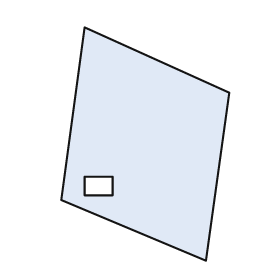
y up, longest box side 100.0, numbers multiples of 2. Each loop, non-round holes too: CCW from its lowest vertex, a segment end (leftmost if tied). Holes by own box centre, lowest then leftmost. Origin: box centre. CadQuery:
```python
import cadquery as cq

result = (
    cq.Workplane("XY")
    .moveTo(26.0, -50.0)
    .lineTo(36.0, 22.0)
    .lineTo(-26.0, 50.0)
    .lineTo(-36.0, -24.0)
    .close()
    .moveTo(-26.0, -22.0)
    .lineTo(-14.0, -22.0)
    .lineTo(-14.0, -14.0)
    .lineTo(-26.0, -14.0)
    .close()
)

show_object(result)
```